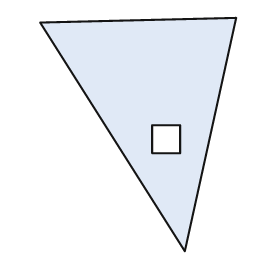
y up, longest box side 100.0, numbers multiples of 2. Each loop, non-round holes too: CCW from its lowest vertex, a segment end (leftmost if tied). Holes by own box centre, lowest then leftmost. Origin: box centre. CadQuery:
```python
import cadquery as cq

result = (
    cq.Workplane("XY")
    .moveTo(20.0, -50.0)
    .lineTo(42.0, 50.0)
    .lineTo(-42.0, 48.0)
    .close()
    .moveTo(6.0, -8.0)
    .lineTo(18.0, -8.0)
    .lineTo(18.0, 4.0)
    .lineTo(6.0, 4.0)
    .close()
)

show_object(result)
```